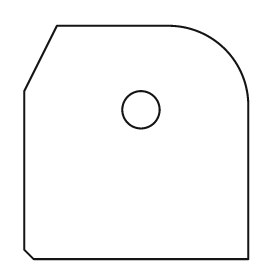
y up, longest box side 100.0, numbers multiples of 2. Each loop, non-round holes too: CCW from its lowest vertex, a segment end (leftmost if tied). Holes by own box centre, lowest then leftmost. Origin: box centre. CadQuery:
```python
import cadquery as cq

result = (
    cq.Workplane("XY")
    .moveTo(-44.0, -50.0)
    .lineTo(48.0, -50.0)
    .lineTo(48.0, 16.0)
    .threePointArc((38.0, 40.0), (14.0, 50.0))
    .lineTo(-34.0, 50.0)
    .lineTo(-48.0, 22.0)
    .lineTo(-48.0, -46.0)
    .close()
    .moveTo(2.0, 14.0)
    .circle(8.0)
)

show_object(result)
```